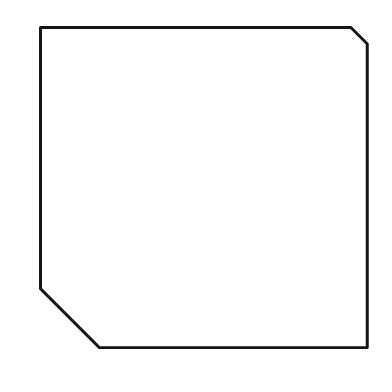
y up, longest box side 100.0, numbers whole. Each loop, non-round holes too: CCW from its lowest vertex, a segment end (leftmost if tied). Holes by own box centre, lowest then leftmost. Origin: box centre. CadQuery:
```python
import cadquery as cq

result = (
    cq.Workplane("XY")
    .moveTo(-32.0, -49.0)
    .lineTo(50.0, -49.0)
    .lineTo(50.0, 44.0)
    .lineTo(45.0, 49.0)
    .lineTo(-50.0, 49.0)
    .lineTo(-50.0, -31.0)
    .close()
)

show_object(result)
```